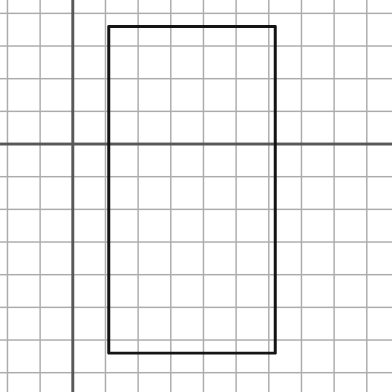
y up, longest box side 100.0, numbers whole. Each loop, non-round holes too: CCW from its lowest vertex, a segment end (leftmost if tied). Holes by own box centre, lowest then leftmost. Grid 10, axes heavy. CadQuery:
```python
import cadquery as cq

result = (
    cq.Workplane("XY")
    .moveTo(11.0, -64.0)
    .lineTo(62.0, -64.0)
    .lineTo(62.0, 36.0)
    .lineTo(11.0, 36.0)
    .close()
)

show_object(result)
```